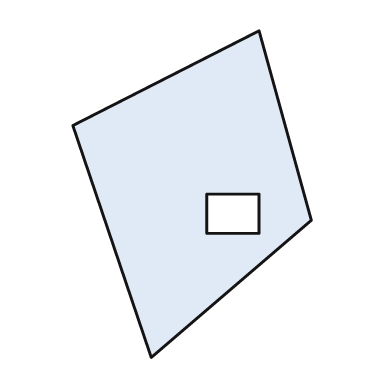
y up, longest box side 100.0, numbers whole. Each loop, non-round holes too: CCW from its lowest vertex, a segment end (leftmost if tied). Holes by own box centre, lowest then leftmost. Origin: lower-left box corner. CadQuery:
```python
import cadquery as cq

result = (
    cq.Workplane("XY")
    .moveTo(24.0, 0.0)
    .lineTo(73.0, 42.0)
    .lineTo(57.0, 100.0)
    .lineTo(0.0, 71.0)
    .close()
    .moveTo(41.0, 38.0)
    .lineTo(57.0, 38.0)
    .lineTo(57.0, 50.0)
    .lineTo(41.0, 50.0)
    .close()
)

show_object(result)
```